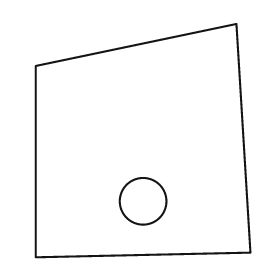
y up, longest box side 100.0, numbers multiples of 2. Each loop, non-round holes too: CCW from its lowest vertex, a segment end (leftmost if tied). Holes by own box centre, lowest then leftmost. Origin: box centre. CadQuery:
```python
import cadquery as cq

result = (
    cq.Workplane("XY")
    .moveTo(-46.0, -50.0)
    .lineTo(46.0, -48.0)
    .lineTo(40.0, 50.0)
    .lineTo(-46.0, 32.0)
    .close()
    .moveTo(0.0, -26.0)
    .circle(10.0)
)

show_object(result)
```